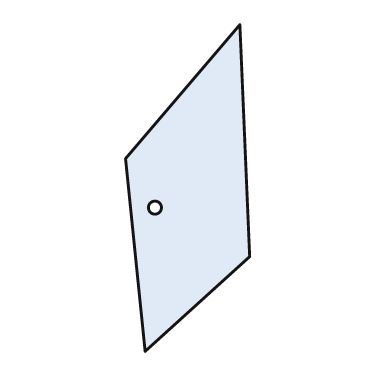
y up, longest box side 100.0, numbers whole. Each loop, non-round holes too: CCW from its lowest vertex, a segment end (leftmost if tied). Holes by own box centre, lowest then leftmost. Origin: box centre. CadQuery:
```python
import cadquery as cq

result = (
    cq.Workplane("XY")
    .moveTo(-13.0, -50.0)
    .lineTo(19.0, -21.0)
    .lineTo(16.0, 50.0)
    .lineTo(-19.0, 9.0)
    .close()
    .moveTo(-10.0, -6.0)
    .circle(2.0)
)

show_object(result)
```